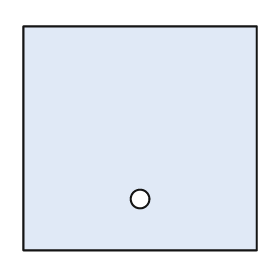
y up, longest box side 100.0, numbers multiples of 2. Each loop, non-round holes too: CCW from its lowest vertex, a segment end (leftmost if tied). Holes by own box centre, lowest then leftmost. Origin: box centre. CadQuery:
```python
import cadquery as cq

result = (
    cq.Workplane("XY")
    .moveTo(-50.0, -48.0)
    .lineTo(50.0, -48.0)
    .lineTo(50.0, 48.0)
    .lineTo(-50.0, 48.0)
    .close()
    .moveTo(0.0, -26.0)
    .circle(4.0)
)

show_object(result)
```